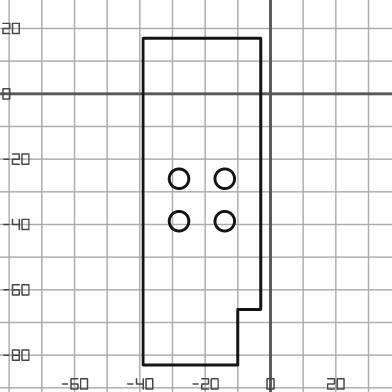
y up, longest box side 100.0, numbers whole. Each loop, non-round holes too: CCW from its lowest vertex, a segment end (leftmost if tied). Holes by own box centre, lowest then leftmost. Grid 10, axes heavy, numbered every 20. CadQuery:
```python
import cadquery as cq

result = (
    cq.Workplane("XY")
    .moveTo(-39.0, -83.0)
    .lineTo(-10.0, -83.0)
    .lineTo(-10.0, -66.0)
    .lineTo(-3.0, -66.0)
    .lineTo(-3.0, 17.0)
    .lineTo(-39.0, 17.0)
    .close()
    .moveTo(-28.0, -39.0)
    .circle(3.0)
    .moveTo(-14.0, -39.0)
    .circle(3.0)
    .moveTo(-28.0, -26.0)
    .circle(3.0)
    .moveTo(-14.0, -26.0)
    .circle(3.0)
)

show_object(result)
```